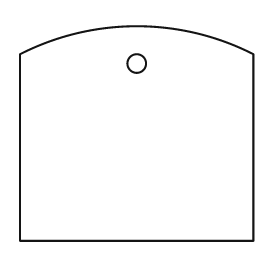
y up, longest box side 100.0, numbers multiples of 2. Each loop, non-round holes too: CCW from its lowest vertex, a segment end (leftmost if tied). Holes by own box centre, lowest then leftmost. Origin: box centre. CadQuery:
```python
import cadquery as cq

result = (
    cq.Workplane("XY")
    .moveTo(-50.0, -46.0)
    .lineTo(50.0, -46.0)
    .lineTo(50.0, 34.0)
    .threePointArc((0.0, 46.0), (-50.0, 34.0))
    .close()
    .moveTo(0.0, 30.0)
    .circle(4.0)
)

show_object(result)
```